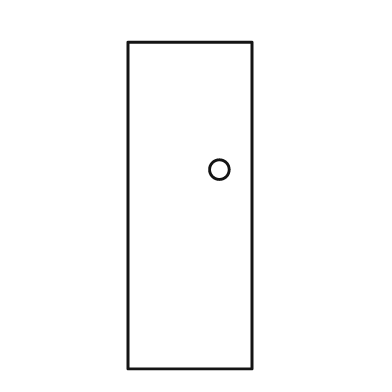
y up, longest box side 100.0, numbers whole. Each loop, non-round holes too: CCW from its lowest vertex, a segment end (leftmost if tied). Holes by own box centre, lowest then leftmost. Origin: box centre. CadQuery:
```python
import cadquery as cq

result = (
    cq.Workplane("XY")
    .moveTo(-19.0, -50.0)
    .lineTo(19.0, -50.0)
    .lineTo(19.0, 50.0)
    .lineTo(-19.0, 50.0)
    .close()
    .moveTo(9.0, 11.0)
    .circle(3.0)
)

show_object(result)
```